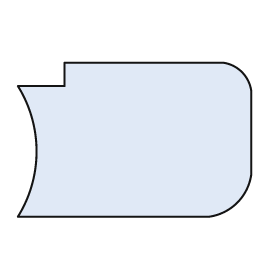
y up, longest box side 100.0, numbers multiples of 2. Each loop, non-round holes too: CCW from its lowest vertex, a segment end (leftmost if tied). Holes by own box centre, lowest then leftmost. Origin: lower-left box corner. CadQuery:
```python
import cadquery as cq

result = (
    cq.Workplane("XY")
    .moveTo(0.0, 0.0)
    .lineTo(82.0, 0.0)
    .threePointArc((94.0, 6.0), (100.0, 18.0))
    .lineTo(100.0, 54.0)
    .threePointArc((96.0, 62.0), (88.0, 66.0))
    .lineTo(20.0, 66.0)
    .lineTo(20.0, 56.0)
    .lineTo(0.0, 56.0)
    .threePointArc((8.0, 28.0), (0.0, 0.0))
    .close()
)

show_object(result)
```